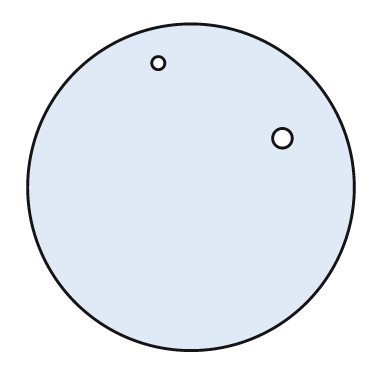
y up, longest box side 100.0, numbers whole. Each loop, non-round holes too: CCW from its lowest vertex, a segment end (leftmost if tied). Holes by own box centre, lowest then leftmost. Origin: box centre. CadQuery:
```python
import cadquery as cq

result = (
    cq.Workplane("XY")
    .moveTo(0.0, 0.0)
    .circle(50.0)
    .moveTo(28.0, 15.0)
    .circle(3.0)
    .moveTo(-10.0, 38.0)
    .circle(2.0)
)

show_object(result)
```